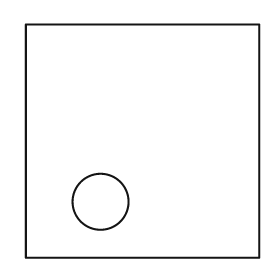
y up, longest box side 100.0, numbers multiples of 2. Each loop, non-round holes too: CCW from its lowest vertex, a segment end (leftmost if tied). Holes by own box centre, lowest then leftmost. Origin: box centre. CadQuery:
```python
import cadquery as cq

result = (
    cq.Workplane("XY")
    .moveTo(-50.0, -50.0)
    .lineTo(50.0, -50.0)
    .lineTo(50.0, 50.0)
    .lineTo(-50.0, 50.0)
    .close()
    .moveTo(-18.0, -26.0)
    .circle(12.0)
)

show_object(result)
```